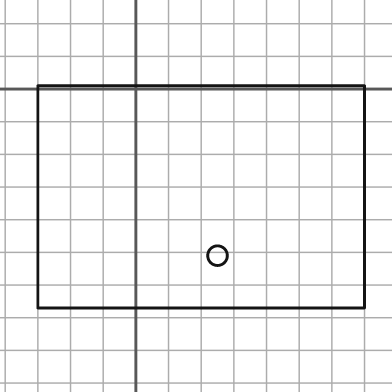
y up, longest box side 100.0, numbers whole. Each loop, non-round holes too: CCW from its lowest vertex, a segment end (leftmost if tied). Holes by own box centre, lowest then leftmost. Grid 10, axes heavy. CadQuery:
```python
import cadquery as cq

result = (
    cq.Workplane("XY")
    .moveTo(-30.0, -67.0)
    .lineTo(70.0, -67.0)
    .lineTo(70.0, 1.0)
    .lineTo(-30.0, 1.0)
    .close()
    .moveTo(25.0, -51.0)
    .circle(3.0)
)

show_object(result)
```